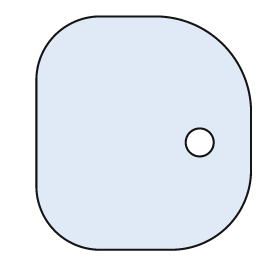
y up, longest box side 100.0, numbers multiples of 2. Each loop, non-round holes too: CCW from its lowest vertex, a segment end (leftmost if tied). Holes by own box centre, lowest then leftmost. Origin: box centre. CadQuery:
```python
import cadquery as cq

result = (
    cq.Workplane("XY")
    .moveTo(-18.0, -50.0)
    .lineTo(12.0, -50.0)
    .threePointArc((36.0, -40.0), (46.0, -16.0))
    .lineTo(46.0, 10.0)
    .threePointArc((34.0, 38.0), (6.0, 50.0))
    .lineTo(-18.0, 50.0)
    .threePointArc((-38.0, 42.0), (-46.0, 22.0))
    .lineTo(-46.0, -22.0)
    .threePointArc((-38.0, -42.0), (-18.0, -50.0))
    .close()
    .moveTo(24.0, -4.0)
    .circle(6.0)
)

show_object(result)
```